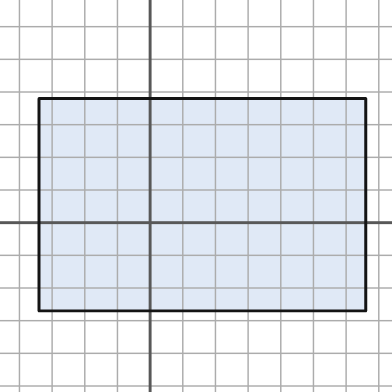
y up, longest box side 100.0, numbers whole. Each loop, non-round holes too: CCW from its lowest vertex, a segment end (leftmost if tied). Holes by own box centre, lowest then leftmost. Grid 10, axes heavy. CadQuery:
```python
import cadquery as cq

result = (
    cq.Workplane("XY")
    .moveTo(-34.0, -27.0)
    .lineTo(66.0, -27.0)
    .lineTo(66.0, 38.0)
    .lineTo(-34.0, 38.0)
    .close()
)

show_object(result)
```